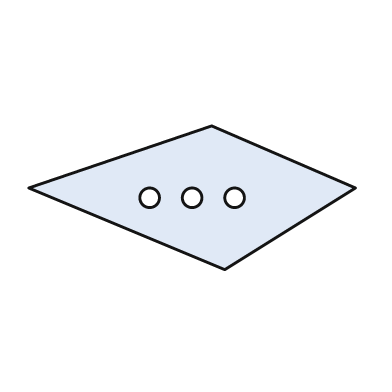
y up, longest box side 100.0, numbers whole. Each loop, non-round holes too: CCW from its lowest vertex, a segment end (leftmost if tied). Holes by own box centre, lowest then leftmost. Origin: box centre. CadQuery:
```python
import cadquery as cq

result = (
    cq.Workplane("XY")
    .moveTo(10.0, -22.0)
    .lineTo(50.0, 3.0)
    .lineTo(6.0, 22.0)
    .lineTo(-50.0, 3.0)
    .close()
    .moveTo(-13.0, 0.0)
    .circle(3.0)
    .moveTo(0.0, 0.0)
    .circle(3.0)
    .moveTo(13.0, 0.0)
    .circle(3.0)
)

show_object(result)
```